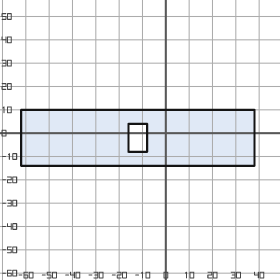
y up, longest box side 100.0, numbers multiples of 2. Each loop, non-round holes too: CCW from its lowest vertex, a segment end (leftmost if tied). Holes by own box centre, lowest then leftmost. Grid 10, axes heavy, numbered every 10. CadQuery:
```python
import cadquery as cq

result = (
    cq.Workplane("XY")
    .moveTo(-62.0, -14.0)
    .lineTo(38.0, -14.0)
    .lineTo(38.0, 10.0)
    .lineTo(-62.0, 10.0)
    .close()
    .moveTo(-16.0, -8.0)
    .lineTo(-8.0, -8.0)
    .lineTo(-8.0, 4.0)
    .lineTo(-16.0, 4.0)
    .close()
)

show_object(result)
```